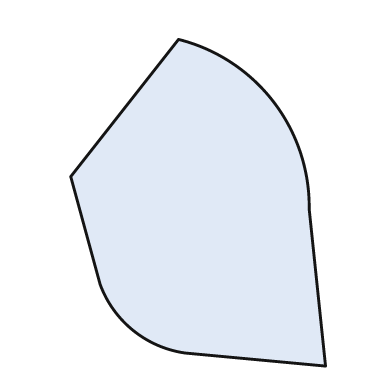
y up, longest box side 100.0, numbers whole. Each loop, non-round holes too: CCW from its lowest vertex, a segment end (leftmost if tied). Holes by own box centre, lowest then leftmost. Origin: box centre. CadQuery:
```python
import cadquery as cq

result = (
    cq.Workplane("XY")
    .moveTo(39.0, -50.0)
    .lineTo(34.0, -2.0)
    .threePointArc((23.0, 31.0), (-6.0, 50.0))
    .lineTo(-39.0, 8.0)
    .lineTo(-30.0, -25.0)
    .threePointArc((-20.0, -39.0), (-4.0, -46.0))
    .close()
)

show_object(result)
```